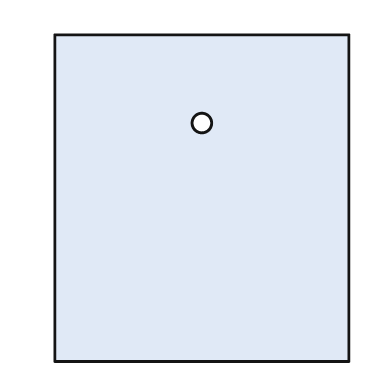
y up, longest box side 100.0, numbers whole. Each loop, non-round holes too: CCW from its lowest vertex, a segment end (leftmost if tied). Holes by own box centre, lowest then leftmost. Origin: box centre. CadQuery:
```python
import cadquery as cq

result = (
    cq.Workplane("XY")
    .moveTo(-45.0, -50.0)
    .lineTo(45.0, -50.0)
    .lineTo(45.0, 50.0)
    .lineTo(-45.0, 50.0)
    .close()
    .moveTo(0.0, 23.0)
    .circle(3.0)
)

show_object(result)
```